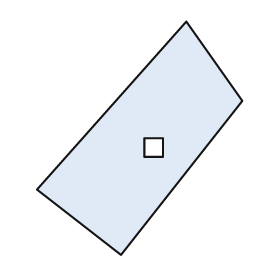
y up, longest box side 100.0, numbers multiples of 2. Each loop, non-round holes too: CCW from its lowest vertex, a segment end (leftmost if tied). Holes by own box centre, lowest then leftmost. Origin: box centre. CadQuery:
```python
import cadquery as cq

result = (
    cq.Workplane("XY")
    .moveTo(-8.0, -50.0)
    .lineTo(44.0, 16.0)
    .lineTo(20.0, 50.0)
    .lineTo(-44.0, -22.0)
    .close()
    .moveTo(2.0, -8.0)
    .lineTo(10.0, -8.0)
    .lineTo(10.0, 0.0)
    .lineTo(2.0, 0.0)
    .close()
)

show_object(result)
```